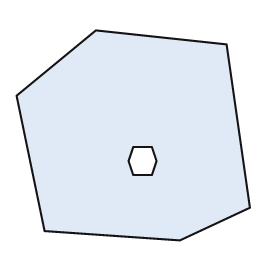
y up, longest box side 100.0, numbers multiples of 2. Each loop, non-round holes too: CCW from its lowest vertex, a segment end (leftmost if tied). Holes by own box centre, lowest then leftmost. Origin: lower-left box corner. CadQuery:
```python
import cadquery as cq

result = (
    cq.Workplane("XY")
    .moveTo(70.0, 0.0)
    .lineTo(100.0, 14.0)
    .lineTo(90.0, 84.0)
    .lineTo(34.0, 90.0)
    .lineTo(0.0, 62.0)
    .lineTo(12.0, 4.0)
    .close()
    .moveTo(50.0, 28.0)
    .lineTo(58.0, 28.0)
    .lineTo(60.0, 34.0)
    .lineTo(58.0, 40.0)
    .lineTo(50.0, 40.0)
    .lineTo(48.0, 34.0)
    .close()
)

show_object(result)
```